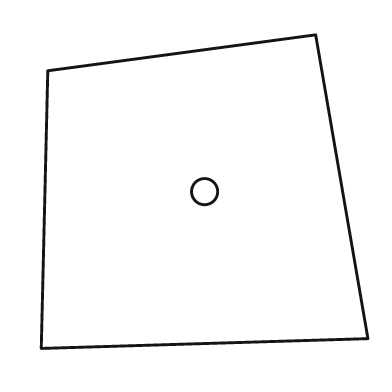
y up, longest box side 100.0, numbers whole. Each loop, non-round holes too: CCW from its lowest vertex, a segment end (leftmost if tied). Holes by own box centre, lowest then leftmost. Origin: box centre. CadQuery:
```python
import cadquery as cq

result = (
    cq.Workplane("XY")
    .moveTo(-50.0, -48.0)
    .lineTo(50.0, -45.0)
    .lineTo(34.0, 48.0)
    .lineTo(-48.0, 37.0)
    .close()
    .moveTo(0.0, 0.0)
    .circle(4.0)
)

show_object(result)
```